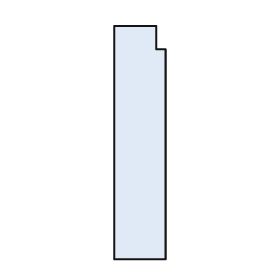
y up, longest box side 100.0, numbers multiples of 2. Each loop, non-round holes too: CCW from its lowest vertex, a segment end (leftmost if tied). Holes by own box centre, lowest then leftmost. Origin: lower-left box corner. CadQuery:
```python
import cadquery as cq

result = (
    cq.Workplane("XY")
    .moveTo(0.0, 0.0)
    .lineTo(22.0, 0.0)
    .lineTo(22.0, 90.0)
    .lineTo(18.0, 90.0)
    .lineTo(18.0, 100.0)
    .lineTo(0.0, 100.0)
    .close()
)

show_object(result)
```